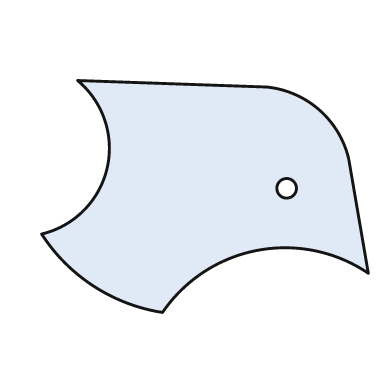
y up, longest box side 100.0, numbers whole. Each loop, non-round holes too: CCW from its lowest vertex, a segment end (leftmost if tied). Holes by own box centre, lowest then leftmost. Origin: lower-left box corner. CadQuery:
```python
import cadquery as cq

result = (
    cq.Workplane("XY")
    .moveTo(37.0, 0.0)
    .threePointArc((66.0, 19.0), (100.0, 12.0))
    .lineTo(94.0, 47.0)
    .threePointArc((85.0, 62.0), (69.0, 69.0))
    .lineTo(11.0, 71.0)
    .threePointArc((20.0, 44.0), (0.0, 24.0))
    .threePointArc((16.0, 8.0), (37.0, 0.0))
    .close()
    .moveTo(75.0, 38.0)
    .circle(3.0)
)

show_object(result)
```